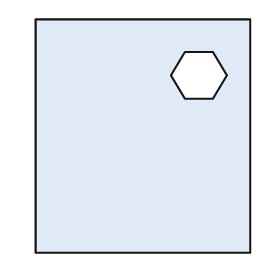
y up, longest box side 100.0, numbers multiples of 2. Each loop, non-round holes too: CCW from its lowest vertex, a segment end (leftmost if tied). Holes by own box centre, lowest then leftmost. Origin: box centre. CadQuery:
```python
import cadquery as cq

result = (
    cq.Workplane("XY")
    .moveTo(-46.0, -50.0)
    .lineTo(46.0, -50.0)
    .lineTo(46.0, 50.0)
    .lineTo(-46.0, 50.0)
    .close()
    .moveTo(18.0, 16.0)
    .lineTo(30.0, 16.0)
    .lineTo(36.0, 26.0)
    .lineTo(30.0, 36.0)
    .lineTo(18.0, 36.0)
    .lineTo(12.0, 26.0)
    .close()
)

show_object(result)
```